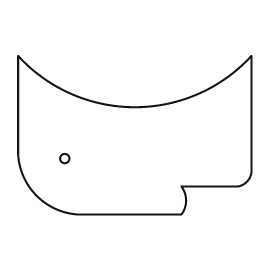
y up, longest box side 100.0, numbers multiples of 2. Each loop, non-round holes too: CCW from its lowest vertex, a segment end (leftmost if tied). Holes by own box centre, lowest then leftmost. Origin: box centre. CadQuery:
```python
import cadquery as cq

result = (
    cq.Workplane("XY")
    .moveTo(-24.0, -34.0)
    .lineTo(20.0, -34.0)
    .threePointArc((22.0, -28.0), (20.0, -22.0))
    .lineTo(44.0, -22.0)
    .threePointArc((48.0, -20.0), (50.0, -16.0))
    .lineTo(50.0, 34.0)
    .threePointArc((0.0, 12.0), (-50.0, 34.0))
    .lineTo(-50.0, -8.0)
    .threePointArc((-42.0, -26.0), (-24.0, -34.0))
    .close()
    .moveTo(-30.0, -10.0)
    .circle(2.0)
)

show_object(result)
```